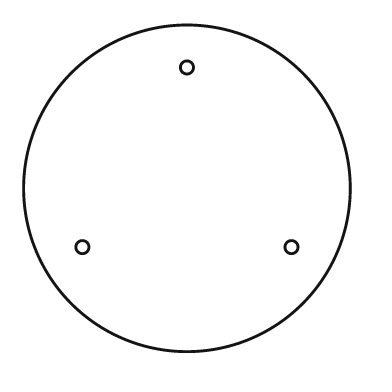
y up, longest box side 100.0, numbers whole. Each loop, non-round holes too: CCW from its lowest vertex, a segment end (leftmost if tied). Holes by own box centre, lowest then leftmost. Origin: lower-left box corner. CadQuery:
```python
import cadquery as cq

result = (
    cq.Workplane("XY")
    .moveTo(50.0, 50.0)
    .circle(50.0)
    .moveTo(18.0, 32.0)
    .circle(2.0)
    .moveTo(82.0, 32.0)
    .circle(2.0)
    .moveTo(50.0, 87.0)
    .circle(2.0)
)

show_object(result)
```